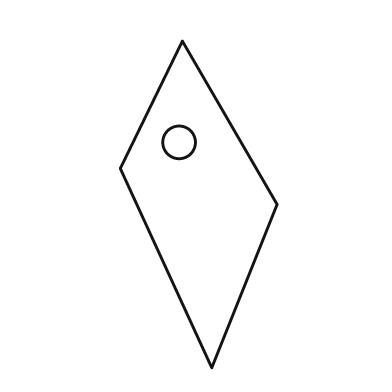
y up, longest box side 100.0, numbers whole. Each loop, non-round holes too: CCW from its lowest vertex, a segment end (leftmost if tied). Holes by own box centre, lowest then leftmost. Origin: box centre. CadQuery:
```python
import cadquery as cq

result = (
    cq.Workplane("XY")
    .moveTo(4.0, -50.0)
    .lineTo(24.0, 0.0)
    .lineTo(-5.0, 50.0)
    .lineTo(-24.0, 11.0)
    .close()
    .moveTo(-6.0, 19.0)
    .circle(5.0)
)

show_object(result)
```